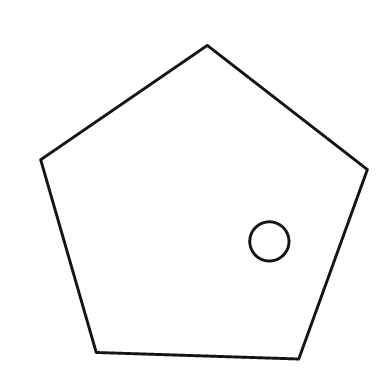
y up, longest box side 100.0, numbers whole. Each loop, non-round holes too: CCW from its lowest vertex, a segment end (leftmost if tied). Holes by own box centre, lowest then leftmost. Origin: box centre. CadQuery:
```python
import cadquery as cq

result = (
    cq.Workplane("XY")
    .moveTo(29.0, -48.0)
    .lineTo(50.0, 10.0)
    .lineTo(1.0, 48.0)
    .lineTo(-50.0, 13.0)
    .lineTo(-33.0, -46.0)
    .close()
    .moveTo(20.0, -12.0)
    .circle(6.0)
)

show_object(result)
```